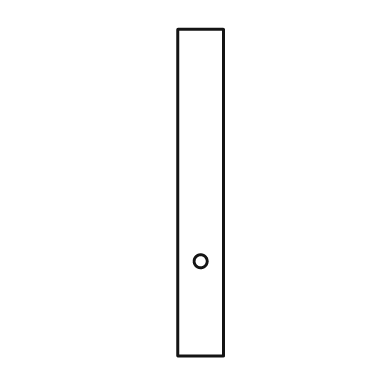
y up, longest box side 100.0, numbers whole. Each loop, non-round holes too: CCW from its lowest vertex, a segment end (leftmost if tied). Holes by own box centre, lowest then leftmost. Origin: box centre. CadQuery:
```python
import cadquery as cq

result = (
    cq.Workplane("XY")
    .moveTo(-7.0, -50.0)
    .lineTo(7.0, -50.0)
    .lineTo(7.0, 50.0)
    .lineTo(-7.0, 50.0)
    .close()
    .moveTo(0.0, -21.0)
    .circle(2.0)
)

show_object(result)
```